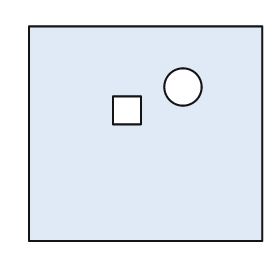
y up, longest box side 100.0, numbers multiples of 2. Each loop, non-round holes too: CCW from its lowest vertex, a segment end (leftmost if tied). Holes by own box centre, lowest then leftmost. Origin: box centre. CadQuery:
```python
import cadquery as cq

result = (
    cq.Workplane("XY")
    .moveTo(-50.0, -46.0)
    .lineTo(50.0, -46.0)
    .lineTo(50.0, 46.0)
    .lineTo(-50.0, 46.0)
    .close()
    .moveTo(-14.0, 4.0)
    .lineTo(-2.0, 4.0)
    .lineTo(-2.0, 16.0)
    .lineTo(-14.0, 16.0)
    .close()
    .moveTo(16.0, 20.0)
    .circle(8.0)
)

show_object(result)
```